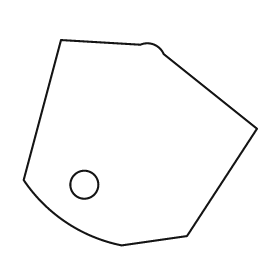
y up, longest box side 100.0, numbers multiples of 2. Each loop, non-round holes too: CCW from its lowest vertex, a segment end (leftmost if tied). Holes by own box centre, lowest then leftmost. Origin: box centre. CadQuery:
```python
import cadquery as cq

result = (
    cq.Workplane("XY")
    .moveTo(-8.0, -44.0)
    .lineTo(20.0, -40.0)
    .lineTo(50.0, 6.0)
    .lineTo(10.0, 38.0)
    .threePointArc((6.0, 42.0), (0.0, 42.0))
    .lineTo(-34.0, 44.0)
    .lineTo(-50.0, -16.0)
    .threePointArc((-32.0, -34.0), (-8.0, -44.0))
    .close()
    .moveTo(-24.0, -18.0)
    .circle(6.0)
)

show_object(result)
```